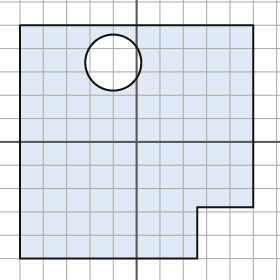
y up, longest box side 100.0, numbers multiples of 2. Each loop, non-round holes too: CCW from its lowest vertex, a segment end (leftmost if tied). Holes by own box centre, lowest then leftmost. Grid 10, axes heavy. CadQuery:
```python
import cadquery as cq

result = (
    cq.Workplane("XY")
    .moveTo(-50.0, -50.0)
    .lineTo(26.0, -50.0)
    .lineTo(26.0, -28.0)
    .lineTo(50.0, -28.0)
    .lineTo(50.0, 50.0)
    .lineTo(-50.0, 50.0)
    .close()
    .moveTo(-10.0, 34.0)
    .circle(12.0)
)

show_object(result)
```